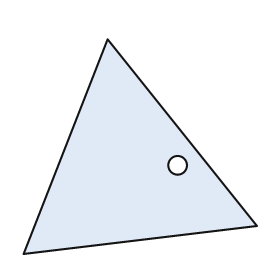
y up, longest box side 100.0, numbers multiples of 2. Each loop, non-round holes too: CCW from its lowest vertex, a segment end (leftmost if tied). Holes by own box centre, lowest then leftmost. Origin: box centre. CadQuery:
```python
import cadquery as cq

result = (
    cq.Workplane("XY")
    .moveTo(-50.0, -46.0)
    .lineTo(50.0, -34.0)
    .lineTo(-14.0, 46.0)
    .close()
    .moveTo(16.0, -8.0)
    .circle(4.0)
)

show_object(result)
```